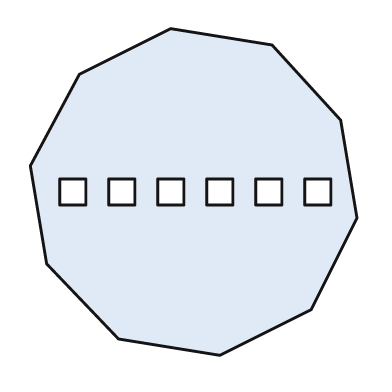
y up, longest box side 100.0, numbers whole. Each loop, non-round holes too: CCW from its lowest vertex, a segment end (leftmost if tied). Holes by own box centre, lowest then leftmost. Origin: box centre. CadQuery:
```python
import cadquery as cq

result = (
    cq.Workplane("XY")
    .moveTo(8.0, -50.0)
    .lineTo(36.0, -36.0)
    .lineTo(50.0, -8.0)
    .lineTo(45.0, 22.0)
    .lineTo(24.0, 45.0)
    .lineTo(-7.0, 50.0)
    .lineTo(-35.0, 36.0)
    .lineTo(-50.0, 8.0)
    .lineTo(-45.0, -22.0)
    .lineTo(-23.0, -45.0)
    .close()
    .moveTo(-41.0, -4.0)
    .lineTo(-33.0, -4.0)
    .lineTo(-33.0, 4.0)
    .lineTo(-41.0, 4.0)
    .close()
    .moveTo(-26.0, -4.0)
    .lineTo(-18.0, -4.0)
    .lineTo(-18.0, 4.0)
    .lineTo(-26.0, 4.0)
    .close()
    .moveTo(-11.0, -4.0)
    .lineTo(-3.0, -4.0)
    .lineTo(-3.0, 4.0)
    .lineTo(-11.0, 4.0)
    .close()
    .moveTo(4.0, -4.0)
    .lineTo(12.0, -4.0)
    .lineTo(12.0, 4.0)
    .lineTo(4.0, 4.0)
    .close()
    .moveTo(19.0, -4.0)
    .lineTo(27.0, -4.0)
    .lineTo(27.0, 4.0)
    .lineTo(19.0, 4.0)
    .close()
    .moveTo(34.0, -4.0)
    .lineTo(42.0, -4.0)
    .lineTo(42.0, 4.0)
    .lineTo(34.0, 4.0)
    .close()
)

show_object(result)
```